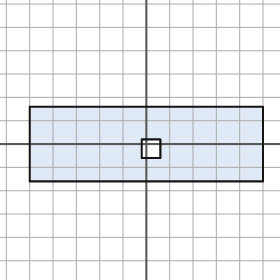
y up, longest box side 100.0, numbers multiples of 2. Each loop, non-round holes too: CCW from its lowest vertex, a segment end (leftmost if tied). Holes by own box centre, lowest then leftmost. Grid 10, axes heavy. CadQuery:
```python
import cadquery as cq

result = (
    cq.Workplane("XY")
    .moveTo(-50.0, -16.0)
    .lineTo(50.0, -16.0)
    .lineTo(50.0, 16.0)
    .lineTo(-50.0, 16.0)
    .close()
    .moveTo(-2.0, -6.0)
    .lineTo(6.0, -6.0)
    .lineTo(6.0, 2.0)
    .lineTo(-2.0, 2.0)
    .close()
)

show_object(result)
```